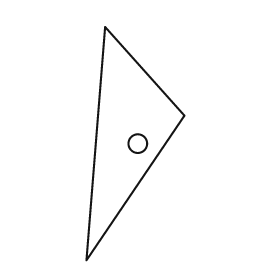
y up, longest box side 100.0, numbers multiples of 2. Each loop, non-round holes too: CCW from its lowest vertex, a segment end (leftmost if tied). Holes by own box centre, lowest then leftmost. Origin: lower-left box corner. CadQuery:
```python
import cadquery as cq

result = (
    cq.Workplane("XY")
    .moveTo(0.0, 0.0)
    .lineTo(42.0, 62.0)
    .lineTo(8.0, 100.0)
    .close()
    .moveTo(22.0, 50.0)
    .circle(4.0)
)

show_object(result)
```